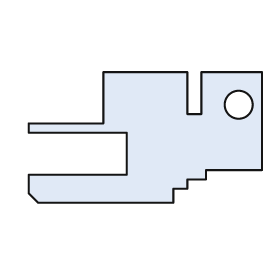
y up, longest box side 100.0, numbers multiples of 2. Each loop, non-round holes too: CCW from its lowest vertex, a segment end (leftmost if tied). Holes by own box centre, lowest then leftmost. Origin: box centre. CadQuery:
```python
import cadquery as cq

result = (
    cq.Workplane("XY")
    .moveTo(-46.0, -28.0)
    .lineTo(12.0, -28.0)
    .lineTo(12.0, -22.0)
    .lineTo(18.0, -22.0)
    .lineTo(18.0, -18.0)
    .lineTo(26.0, -18.0)
    .lineTo(26.0, -14.0)
    .lineTo(50.0, -14.0)
    .lineTo(50.0, 28.0)
    .lineTo(24.0, 28.0)
    .lineTo(24.0, 10.0)
    .lineTo(18.0, 10.0)
    .lineTo(18.0, 28.0)
    .lineTo(-18.0, 28.0)
    .lineTo(-18.0, 6.0)
    .lineTo(-50.0, 6.0)
    .lineTo(-50.0, 2.0)
    .lineTo(-8.0, 2.0)
    .lineTo(-8.0, -16.0)
    .lineTo(-50.0, -16.0)
    .lineTo(-50.0, -24.0)
    .close()
    .moveTo(40.0, 14.0)
    .circle(6.0)
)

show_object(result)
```